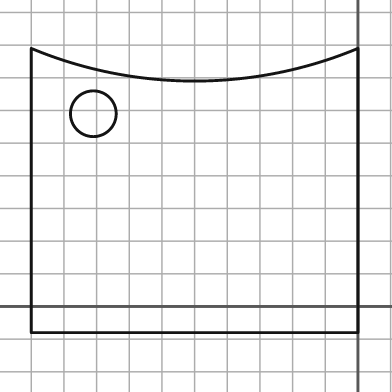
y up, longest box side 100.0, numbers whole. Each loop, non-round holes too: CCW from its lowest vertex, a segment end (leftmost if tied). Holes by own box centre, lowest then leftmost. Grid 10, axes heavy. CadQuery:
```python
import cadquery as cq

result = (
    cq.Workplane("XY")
    .moveTo(-100.0, -8.0)
    .lineTo(0.0, -8.0)
    .lineTo(0.0, 79.0)
    .threePointArc((-50.0, 69.0), (-100.0, 79.0))
    .close()
    .moveTo(-81.0, 59.0)
    .circle(7.0)
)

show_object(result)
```